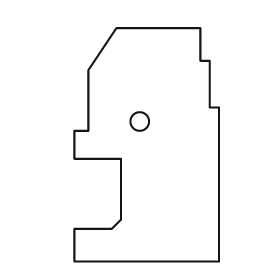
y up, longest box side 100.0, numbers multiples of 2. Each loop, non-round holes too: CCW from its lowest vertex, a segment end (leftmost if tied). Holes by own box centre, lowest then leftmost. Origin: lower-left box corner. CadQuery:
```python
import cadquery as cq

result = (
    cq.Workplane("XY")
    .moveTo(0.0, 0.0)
    .lineTo(62.0, 0.0)
    .lineTo(62.0, 66.0)
    .lineTo(58.0, 66.0)
    .lineTo(58.0, 86.0)
    .lineTo(54.0, 86.0)
    .lineTo(54.0, 100.0)
    .lineTo(18.0, 100.0)
    .lineTo(6.0, 82.0)
    .lineTo(6.0, 56.0)
    .lineTo(0.0, 56.0)
    .lineTo(0.0, 44.0)
    .lineTo(20.0, 44.0)
    .lineTo(20.0, 18.0)
    .lineTo(16.0, 14.0)
    .lineTo(0.0, 14.0)
    .close()
    .moveTo(28.0, 60.0)
    .circle(4.0)
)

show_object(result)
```